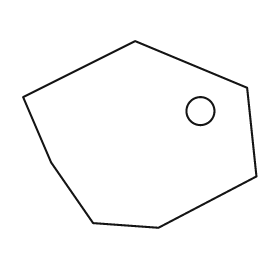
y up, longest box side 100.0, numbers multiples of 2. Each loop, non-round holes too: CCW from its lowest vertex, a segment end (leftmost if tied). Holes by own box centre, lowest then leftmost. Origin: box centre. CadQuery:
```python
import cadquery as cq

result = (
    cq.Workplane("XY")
    .moveTo(8.0, -40.0)
    .lineTo(50.0, -18.0)
    .lineTo(46.0, 20.0)
    .lineTo(-2.0, 40.0)
    .lineTo(-50.0, 16.0)
    .lineTo(-38.0, -12.0)
    .lineTo(-20.0, -38.0)
    .close()
    .moveTo(26.0, 10.0)
    .circle(6.0)
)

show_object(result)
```